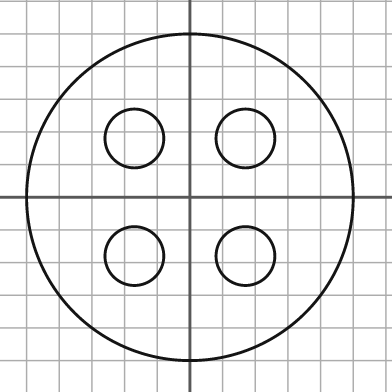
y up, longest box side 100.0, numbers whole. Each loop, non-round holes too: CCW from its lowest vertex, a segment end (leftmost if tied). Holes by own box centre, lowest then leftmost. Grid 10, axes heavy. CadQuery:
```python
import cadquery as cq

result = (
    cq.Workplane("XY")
    .moveTo(0.0, 0.0)
    .circle(50.0)
    .moveTo(-17.0, -18.0)
    .circle(9.0)
    .moveTo(17.0, -18.0)
    .circle(9.0)
    .moveTo(-17.0, 18.0)
    .circle(9.0)
    .moveTo(17.0, 18.0)
    .circle(9.0)
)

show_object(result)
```